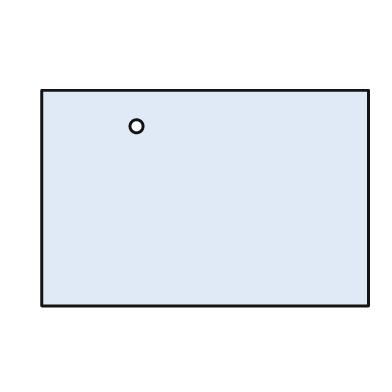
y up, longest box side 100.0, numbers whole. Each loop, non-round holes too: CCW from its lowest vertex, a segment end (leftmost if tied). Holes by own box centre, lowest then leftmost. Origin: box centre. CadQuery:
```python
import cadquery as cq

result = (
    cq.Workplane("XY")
    .moveTo(-50.0, -33.0)
    .lineTo(50.0, -33.0)
    .lineTo(50.0, 33.0)
    .lineTo(-50.0, 33.0)
    .close()
    .moveTo(-21.0, 22.0)
    .circle(2.0)
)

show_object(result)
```